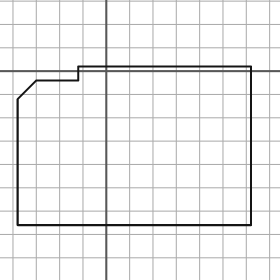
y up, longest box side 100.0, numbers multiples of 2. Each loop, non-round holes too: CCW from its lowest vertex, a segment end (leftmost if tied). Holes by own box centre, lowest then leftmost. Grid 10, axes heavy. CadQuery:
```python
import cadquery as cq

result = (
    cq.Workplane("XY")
    .moveTo(-38.0, -66.0)
    .lineTo(62.0, -66.0)
    .lineTo(62.0, 2.0)
    .lineTo(-12.0, 2.0)
    .lineTo(-12.0, -4.0)
    .lineTo(-30.0, -4.0)
    .lineTo(-38.0, -12.0)
    .close()
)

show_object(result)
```